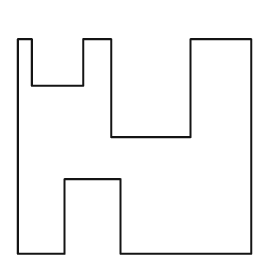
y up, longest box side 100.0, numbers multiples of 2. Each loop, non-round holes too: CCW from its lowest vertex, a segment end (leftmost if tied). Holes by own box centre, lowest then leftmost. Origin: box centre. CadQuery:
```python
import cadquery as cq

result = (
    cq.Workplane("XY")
    .moveTo(-50.0, -46.0)
    .lineTo(-30.0, -46.0)
    .lineTo(-30.0, -14.0)
    .lineTo(-6.0, -14.0)
    .lineTo(-6.0, -46.0)
    .lineTo(50.0, -46.0)
    .lineTo(50.0, 46.0)
    .lineTo(24.0, 46.0)
    .lineTo(24.0, 4.0)
    .lineTo(-10.0, 4.0)
    .lineTo(-10.0, 46.0)
    .lineTo(-22.0, 46.0)
    .lineTo(-22.0, 26.0)
    .lineTo(-44.0, 26.0)
    .lineTo(-44.0, 46.0)
    .lineTo(-50.0, 46.0)
    .close()
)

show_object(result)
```